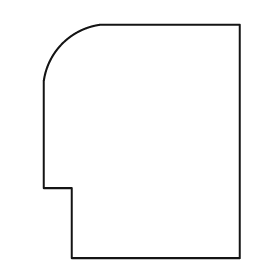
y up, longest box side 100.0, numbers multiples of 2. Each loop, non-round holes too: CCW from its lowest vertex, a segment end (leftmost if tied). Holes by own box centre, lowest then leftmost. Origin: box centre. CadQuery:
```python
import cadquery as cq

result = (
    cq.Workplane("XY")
    .moveTo(-30.0, -50.0)
    .lineTo(42.0, -50.0)
    .lineTo(42.0, 50.0)
    .lineTo(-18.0, 50.0)
    .threePointArc((-34.0, 42.0), (-42.0, 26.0))
    .lineTo(-42.0, -20.0)
    .lineTo(-30.0, -20.0)
    .close()
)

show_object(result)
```